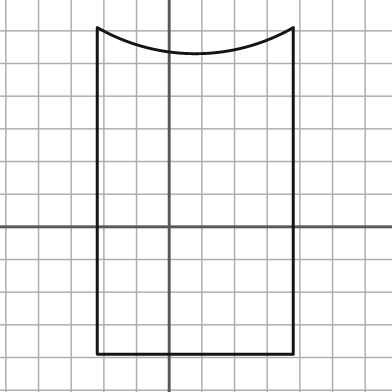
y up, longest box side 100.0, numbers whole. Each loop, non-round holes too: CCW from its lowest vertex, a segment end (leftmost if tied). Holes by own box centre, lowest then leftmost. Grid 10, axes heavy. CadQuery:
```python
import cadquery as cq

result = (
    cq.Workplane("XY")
    .moveTo(-22.0, -39.0)
    .lineTo(38.0, -39.0)
    .lineTo(38.0, 61.0)
    .threePointArc((8.0, 53.0), (-22.0, 61.0))
    .close()
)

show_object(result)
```